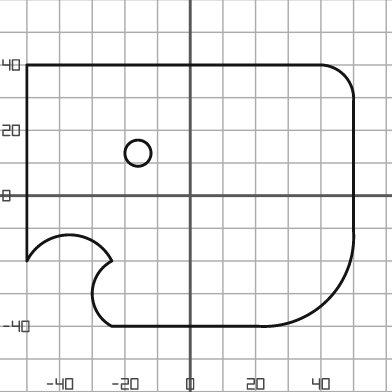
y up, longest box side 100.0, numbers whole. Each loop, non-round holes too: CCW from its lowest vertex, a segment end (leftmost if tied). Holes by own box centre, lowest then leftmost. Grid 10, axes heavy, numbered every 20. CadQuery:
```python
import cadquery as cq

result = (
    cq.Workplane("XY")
    .moveTo(-24.0, -40.0)
    .lineTo(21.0, -40.0)
    .threePointArc((42.0, -32.0), (50.0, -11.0))
    .lineTo(50.0, 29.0)
    .threePointArc((47.0, 37.0), (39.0, 40.0))
    .lineTo(-50.0, 40.0)
    .lineTo(-50.0, -20.0)
    .threePointArc((-37.0, -12.0), (-24.0, -20.0))
    .threePointArc((-30.0, -30.0), (-24.0, -40.0))
    .close()
    .moveTo(-16.0, 13.0)
    .circle(4.0)
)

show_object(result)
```